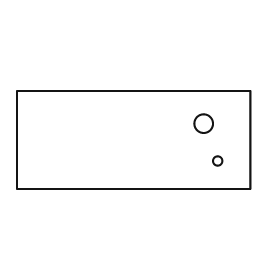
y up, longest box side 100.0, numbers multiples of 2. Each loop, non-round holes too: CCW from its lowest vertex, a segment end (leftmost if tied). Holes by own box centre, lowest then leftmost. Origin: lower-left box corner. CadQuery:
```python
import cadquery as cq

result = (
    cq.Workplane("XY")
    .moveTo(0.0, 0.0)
    .lineTo(100.0, 0.0)
    .lineTo(100.0, 42.0)
    .lineTo(0.0, 42.0)
    .close()
    .moveTo(86.0, 12.0)
    .circle(2.0)
    .moveTo(80.0, 28.0)
    .circle(4.0)
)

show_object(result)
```